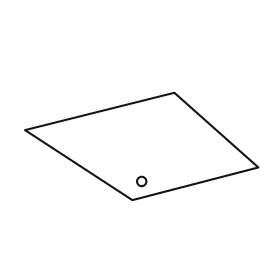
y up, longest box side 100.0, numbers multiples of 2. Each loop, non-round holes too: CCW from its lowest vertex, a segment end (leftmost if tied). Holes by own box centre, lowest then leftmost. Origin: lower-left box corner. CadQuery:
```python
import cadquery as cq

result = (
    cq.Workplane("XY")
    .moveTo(46.0, 0.0)
    .lineTo(100.0, 14.0)
    .lineTo(64.0, 46.0)
    .lineTo(0.0, 30.0)
    .close()
    .moveTo(50.0, 8.0)
    .circle(2.0)
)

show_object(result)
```